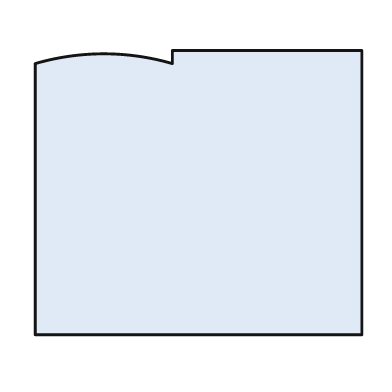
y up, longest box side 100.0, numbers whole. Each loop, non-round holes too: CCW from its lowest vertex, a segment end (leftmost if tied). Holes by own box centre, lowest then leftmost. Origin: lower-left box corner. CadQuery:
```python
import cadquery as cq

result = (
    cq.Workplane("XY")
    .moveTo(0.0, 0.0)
    .lineTo(100.0, 0.0)
    .lineTo(100.0, 87.0)
    .lineTo(42.0, 87.0)
    .lineTo(42.0, 83.0)
    .threePointArc((21.0, 86.0), (0.0, 83.0))
    .close()
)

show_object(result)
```